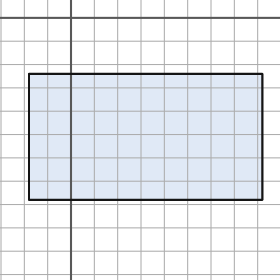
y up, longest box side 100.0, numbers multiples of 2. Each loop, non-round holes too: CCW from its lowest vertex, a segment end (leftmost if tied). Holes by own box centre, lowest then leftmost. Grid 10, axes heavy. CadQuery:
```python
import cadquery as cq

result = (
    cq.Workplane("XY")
    .moveTo(-18.0, -78.0)
    .lineTo(82.0, -78.0)
    .lineTo(82.0, -24.0)
    .lineTo(-18.0, -24.0)
    .close()
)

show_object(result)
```